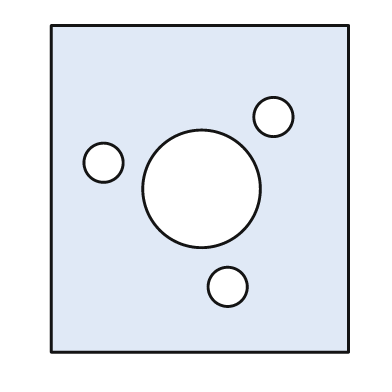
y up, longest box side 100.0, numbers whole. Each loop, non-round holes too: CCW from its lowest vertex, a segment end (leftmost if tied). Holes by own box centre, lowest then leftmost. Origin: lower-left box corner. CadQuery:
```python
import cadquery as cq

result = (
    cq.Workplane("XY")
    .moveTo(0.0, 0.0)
    .lineTo(91.0, 0.0)
    .lineTo(91.0, 100.0)
    .lineTo(0.0, 100.0)
    .close()
    .moveTo(54.0, 20.0)
    .circle(6.0)
    .moveTo(46.0, 50.0)
    .circle(18.0)
    .moveTo(16.0, 58.0)
    .circle(6.0)
    .moveTo(68.0, 72.0)
    .circle(6.0)
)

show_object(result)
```